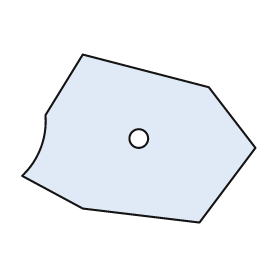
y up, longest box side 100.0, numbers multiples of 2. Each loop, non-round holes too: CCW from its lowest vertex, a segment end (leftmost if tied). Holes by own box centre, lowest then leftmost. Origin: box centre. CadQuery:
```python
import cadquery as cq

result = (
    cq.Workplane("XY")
    .moveTo(26.0, -36.0)
    .lineTo(50.0, -4.0)
    .lineTo(30.0, 22.0)
    .lineTo(-24.0, 36.0)
    .lineTo(-40.0, 10.0)
    .threePointArc((-42.0, -4.0), (-50.0, -16.0))
    .lineTo(-24.0, -30.0)
    .close()
    .moveTo(0.0, 0.0)
    .circle(4.0)
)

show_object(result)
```